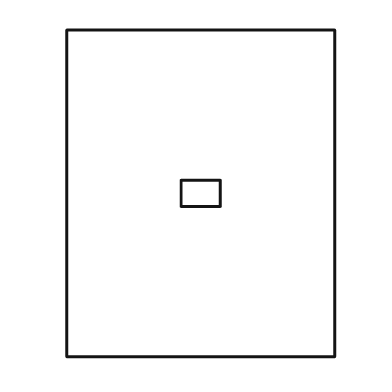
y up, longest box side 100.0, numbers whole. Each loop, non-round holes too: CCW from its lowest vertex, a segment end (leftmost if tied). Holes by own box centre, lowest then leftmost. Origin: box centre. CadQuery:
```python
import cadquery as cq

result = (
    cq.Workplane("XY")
    .moveTo(-41.0, -50.0)
    .lineTo(41.0, -50.0)
    .lineTo(41.0, 50.0)
    .lineTo(-41.0, 50.0)
    .close()
    .moveTo(-6.0, -4.0)
    .lineTo(6.0, -4.0)
    .lineTo(6.0, 4.0)
    .lineTo(-6.0, 4.0)
    .close()
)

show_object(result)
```